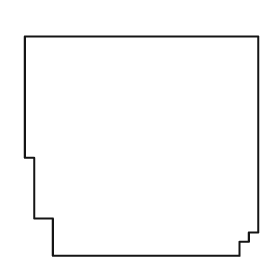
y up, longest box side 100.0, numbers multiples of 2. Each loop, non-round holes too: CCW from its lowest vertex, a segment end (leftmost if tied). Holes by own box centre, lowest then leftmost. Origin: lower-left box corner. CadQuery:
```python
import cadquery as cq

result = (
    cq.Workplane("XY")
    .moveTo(12.0, 0.0)
    .lineTo(92.0, 0.0)
    .lineTo(92.0, 6.0)
    .lineTo(96.0, 6.0)
    .lineTo(96.0, 10.0)
    .lineTo(100.0, 10.0)
    .lineTo(100.0, 94.0)
    .lineTo(0.0, 94.0)
    .lineTo(0.0, 42.0)
    .lineTo(4.0, 42.0)
    .lineTo(4.0, 16.0)
    .lineTo(12.0, 16.0)
    .close()
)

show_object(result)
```